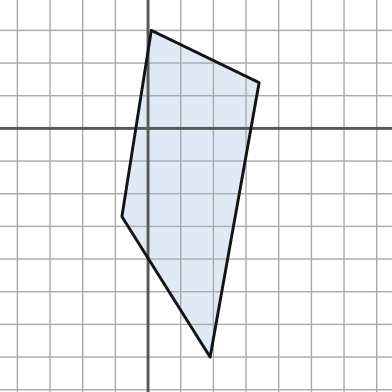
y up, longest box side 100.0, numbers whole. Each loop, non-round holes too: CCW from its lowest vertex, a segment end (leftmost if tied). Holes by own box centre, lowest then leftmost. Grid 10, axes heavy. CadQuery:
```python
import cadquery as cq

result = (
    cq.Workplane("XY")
    .moveTo(19.0, -70.0)
    .lineTo(34.0, 14.0)
    .lineTo(1.0, 30.0)
    .lineTo(-8.0, -27.0)
    .close()
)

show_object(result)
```